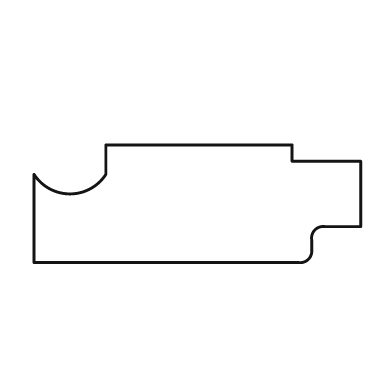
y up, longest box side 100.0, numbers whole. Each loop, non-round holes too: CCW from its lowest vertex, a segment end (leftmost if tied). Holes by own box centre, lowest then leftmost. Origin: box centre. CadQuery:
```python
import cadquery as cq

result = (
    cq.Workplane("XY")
    .moveTo(-50.0, -18.0)
    .lineTo(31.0, -18.0)
    .threePointArc((34.0, -17.0), (35.0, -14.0))
    .lineTo(35.0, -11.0)
    .threePointArc((36.0, -8.0), (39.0, -7.0))
    .lineTo(50.0, -7.0)
    .lineTo(50.0, 13.0)
    .lineTo(29.0, 13.0)
    .lineTo(29.0, 18.0)
    .lineTo(-28.0, 18.0)
    .lineTo(-28.0, 9.0)
    .threePointArc((-39.0, 3.0), (-50.0, 9.0))
    .close()
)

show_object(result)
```